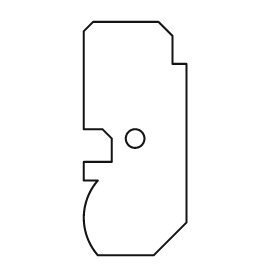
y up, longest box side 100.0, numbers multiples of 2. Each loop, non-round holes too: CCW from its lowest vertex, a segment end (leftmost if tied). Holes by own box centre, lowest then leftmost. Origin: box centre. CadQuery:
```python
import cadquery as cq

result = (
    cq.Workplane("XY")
    .moveTo(-16.0, -50.0)
    .lineTo(8.0, -50.0)
    .lineTo(22.0, -36.0)
    .lineTo(22.0, 32.0)
    .lineTo(16.0, 32.0)
    .lineTo(16.0, 44.0)
    .lineTo(10.0, 50.0)
    .lineTo(-18.0, 50.0)
    .lineTo(-22.0, 46.0)
    .lineTo(-22.0, 4.0)
    .lineTo(-14.0, 4.0)
    .lineTo(-10.0, 0.0)
    .lineTo(-10.0, -10.0)
    .lineTo(-22.0, -10.0)
    .lineTo(-22.0, -18.0)
    .lineTo(-16.0, -18.0)
    .threePointArc((-22.0, -34.0), (-16.0, -50.0))
    .close()
    .moveTo(0.0, 0.0)
    .circle(4.0)
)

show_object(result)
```